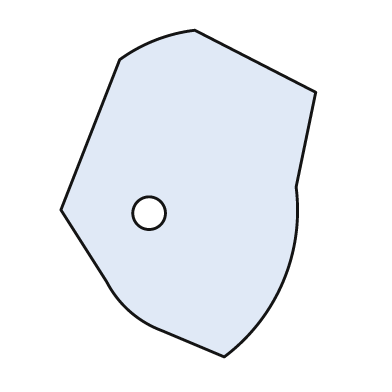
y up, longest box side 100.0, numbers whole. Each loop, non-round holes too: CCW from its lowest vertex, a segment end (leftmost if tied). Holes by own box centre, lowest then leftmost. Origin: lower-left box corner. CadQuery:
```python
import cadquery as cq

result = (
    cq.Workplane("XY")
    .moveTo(50.0, 0.0)
    .threePointArc((68.0, 23.0), (72.0, 52.0))
    .lineTo(78.0, 81.0)
    .lineTo(41.0, 100.0)
    .threePointArc((29.0, 97.0), (18.0, 91.0))
    .lineTo(0.0, 45.0)
    .lineTo(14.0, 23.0)
    .threePointArc((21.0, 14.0), (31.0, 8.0))
    .close()
    .moveTo(27.0, 44.0)
    .circle(5.0)
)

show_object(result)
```